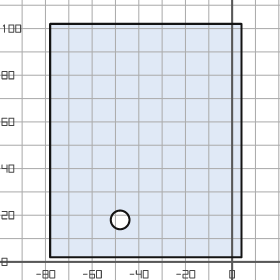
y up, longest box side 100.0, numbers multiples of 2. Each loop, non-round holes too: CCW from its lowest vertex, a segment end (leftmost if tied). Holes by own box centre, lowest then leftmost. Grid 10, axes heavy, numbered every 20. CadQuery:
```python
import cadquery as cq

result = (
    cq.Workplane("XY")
    .moveTo(-78.0, 2.0)
    .lineTo(4.0, 2.0)
    .lineTo(4.0, 102.0)
    .lineTo(-78.0, 102.0)
    .close()
    .moveTo(-48.0, 18.0)
    .circle(4.0)
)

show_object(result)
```